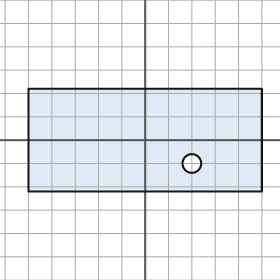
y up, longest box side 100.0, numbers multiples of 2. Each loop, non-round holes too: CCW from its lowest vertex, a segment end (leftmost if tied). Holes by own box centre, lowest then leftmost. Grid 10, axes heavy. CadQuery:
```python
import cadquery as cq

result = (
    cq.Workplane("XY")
    .moveTo(-50.0, -22.0)
    .lineTo(50.0, -22.0)
    .lineTo(50.0, 22.0)
    .lineTo(-50.0, 22.0)
    .close()
    .moveTo(20.0, -10.0)
    .circle(4.0)
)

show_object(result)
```